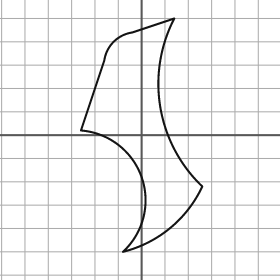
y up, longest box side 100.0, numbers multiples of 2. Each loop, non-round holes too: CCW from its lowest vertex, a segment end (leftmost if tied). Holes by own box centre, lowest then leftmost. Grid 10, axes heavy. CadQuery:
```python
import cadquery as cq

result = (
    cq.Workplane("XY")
    .moveTo(-8.0, -50.0)
    .threePointArc((12.0, -40.0), (26.0, -22.0))
    .threePointArc((8.0, 12.0), (14.0, 50.0))
    .lineTo(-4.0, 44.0)
    .threePointArc((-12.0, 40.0), (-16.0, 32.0))
    .lineTo(-26.0, 2.0)
    .threePointArc((0.0, -18.0), (-8.0, -50.0))
    .close()
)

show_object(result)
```